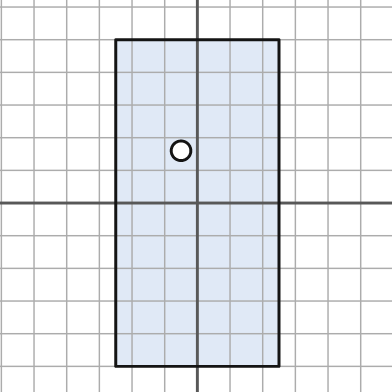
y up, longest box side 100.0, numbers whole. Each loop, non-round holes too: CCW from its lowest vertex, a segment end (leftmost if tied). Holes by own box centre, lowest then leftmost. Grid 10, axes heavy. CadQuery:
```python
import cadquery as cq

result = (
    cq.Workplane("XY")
    .moveTo(-25.0, -50.0)
    .lineTo(25.0, -50.0)
    .lineTo(25.0, 50.0)
    .lineTo(-25.0, 50.0)
    .close()
    .moveTo(-5.0, 16.0)
    .circle(3.0)
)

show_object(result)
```